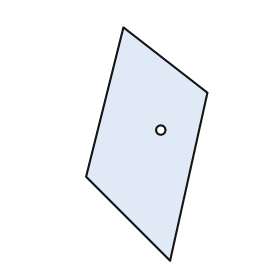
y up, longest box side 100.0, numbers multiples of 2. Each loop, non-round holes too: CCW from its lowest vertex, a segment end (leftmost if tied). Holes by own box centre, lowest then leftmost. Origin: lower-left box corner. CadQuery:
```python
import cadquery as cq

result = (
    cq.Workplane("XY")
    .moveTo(36.0, 0.0)
    .lineTo(52.0, 72.0)
    .lineTo(16.0, 100.0)
    .lineTo(0.0, 36.0)
    .close()
    .moveTo(32.0, 56.0)
    .circle(2.0)
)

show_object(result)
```